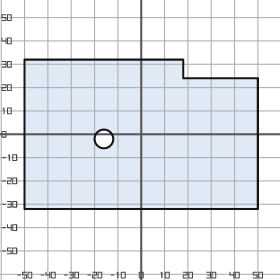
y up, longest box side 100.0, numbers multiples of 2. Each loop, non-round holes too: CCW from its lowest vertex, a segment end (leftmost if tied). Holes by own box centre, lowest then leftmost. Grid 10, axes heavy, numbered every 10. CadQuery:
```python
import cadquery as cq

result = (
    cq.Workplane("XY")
    .moveTo(-50.0, -32.0)
    .lineTo(50.0, -32.0)
    .lineTo(50.0, 24.0)
    .lineTo(18.0, 24.0)
    .lineTo(18.0, 32.0)
    .lineTo(-50.0, 32.0)
    .close()
    .moveTo(-16.0, -2.0)
    .circle(4.0)
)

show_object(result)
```